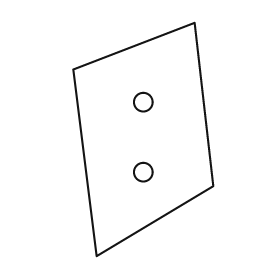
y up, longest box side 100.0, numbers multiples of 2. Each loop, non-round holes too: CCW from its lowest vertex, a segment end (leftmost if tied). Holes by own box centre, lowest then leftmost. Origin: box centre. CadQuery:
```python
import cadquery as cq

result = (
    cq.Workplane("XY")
    .moveTo(-20.0, -50.0)
    .lineTo(30.0, -20.0)
    .lineTo(22.0, 50.0)
    .lineTo(-30.0, 30.0)
    .close()
    .moveTo(0.0, -14.0)
    .circle(4.0)
    .moveTo(0.0, 16.0)
    .circle(4.0)
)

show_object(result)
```